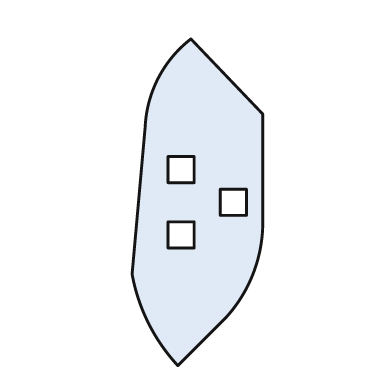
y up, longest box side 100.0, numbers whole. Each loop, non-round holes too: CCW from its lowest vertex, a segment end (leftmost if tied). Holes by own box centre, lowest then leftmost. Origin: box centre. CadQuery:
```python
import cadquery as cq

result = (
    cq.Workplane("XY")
    .moveTo(-6.0, -50.0)
    .lineTo(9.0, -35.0)
    .threePointArc((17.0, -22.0), (20.0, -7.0))
    .lineTo(20.0, 27.0)
    .lineTo(-2.0, 50.0)
    .threePointArc((-12.0, 38.0), (-16.0, 23.0))
    .lineTo(-20.0, -22.0)
    .threePointArc((-15.0, -37.0), (-6.0, -50.0))
    .close()
    .moveTo(-9.0, -14.0)
    .lineTo(-1.0, -14.0)
    .lineTo(-1.0, -6.0)
    .lineTo(-9.0, -6.0)
    .close()
    .moveTo(7.0, -4.0)
    .lineTo(15.0, -4.0)
    .lineTo(15.0, 4.0)
    .lineTo(7.0, 4.0)
    .close()
    .moveTo(-9.0, 6.0)
    .lineTo(-1.0, 6.0)
    .lineTo(-1.0, 14.0)
    .lineTo(-9.0, 14.0)
    .close()
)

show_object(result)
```